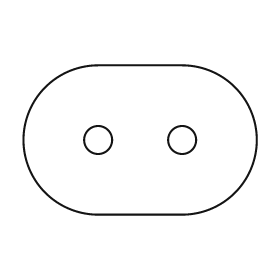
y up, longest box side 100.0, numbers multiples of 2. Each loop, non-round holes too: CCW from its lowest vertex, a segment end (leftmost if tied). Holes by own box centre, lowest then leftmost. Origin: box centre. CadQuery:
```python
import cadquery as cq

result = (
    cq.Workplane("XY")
    .moveTo(-18.0, -32.0)
    .lineTo(18.0, -32.0)
    .threePointArc((50.0, 0.0), (18.0, 32.0))
    .lineTo(-18.0, 32.0)
    .threePointArc((-50.0, 0.0), (-18.0, -32.0))
    .close()
    .moveTo(-18.0, 0.0)
    .circle(6.0)
    .moveTo(18.0, 0.0)
    .circle(6.0)
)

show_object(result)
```